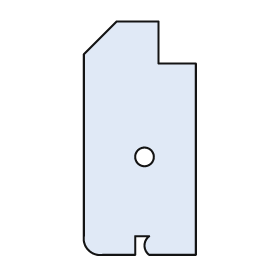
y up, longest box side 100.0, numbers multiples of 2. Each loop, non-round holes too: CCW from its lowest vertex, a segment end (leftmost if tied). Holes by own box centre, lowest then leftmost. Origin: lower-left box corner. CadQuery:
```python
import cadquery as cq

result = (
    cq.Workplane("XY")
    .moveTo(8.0, 0.0)
    .lineTo(22.0, 0.0)
    .lineTo(22.0, 8.0)
    .lineTo(28.0, 8.0)
    .threePointArc((26.0, 4.0), (28.0, 0.0))
    .lineTo(48.0, 0.0)
    .lineTo(48.0, 82.0)
    .lineTo(32.0, 82.0)
    .lineTo(32.0, 100.0)
    .lineTo(14.0, 100.0)
    .lineTo(0.0, 86.0)
    .lineTo(0.0, 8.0)
    .threePointArc((2.0, 2.0), (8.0, 0.0))
    .close()
    .moveTo(26.0, 42.0)
    .circle(4.0)
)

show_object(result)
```